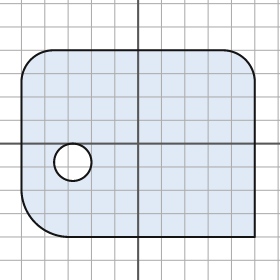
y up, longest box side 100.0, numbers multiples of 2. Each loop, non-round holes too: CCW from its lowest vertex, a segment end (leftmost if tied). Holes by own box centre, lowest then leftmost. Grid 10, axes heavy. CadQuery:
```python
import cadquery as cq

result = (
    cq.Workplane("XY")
    .moveTo(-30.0, -40.0)
    .lineTo(50.0, -40.0)
    .lineTo(50.0, 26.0)
    .threePointArc((46.0, 36.0), (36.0, 40.0))
    .lineTo(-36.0, 40.0)
    .threePointArc((-46.0, 36.0), (-50.0, 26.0))
    .lineTo(-50.0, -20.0)
    .threePointArc((-44.0, -34.0), (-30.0, -40.0))
    .close()
    .moveTo(-28.0, -8.0)
    .circle(8.0)
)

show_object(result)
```